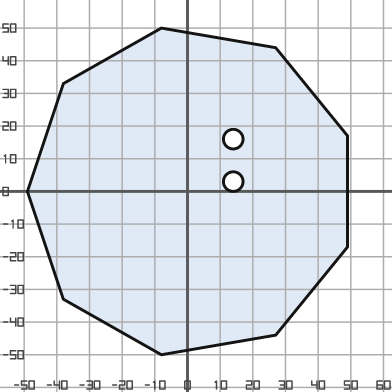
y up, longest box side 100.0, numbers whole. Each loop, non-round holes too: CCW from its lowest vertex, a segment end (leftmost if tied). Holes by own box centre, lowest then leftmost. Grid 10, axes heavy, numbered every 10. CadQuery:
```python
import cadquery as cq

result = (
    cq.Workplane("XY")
    .moveTo(-8.0, -50.0)
    .lineTo(27.0, -44.0)
    .lineTo(49.0, -17.0)
    .lineTo(49.0, 17.0)
    .lineTo(27.0, 44.0)
    .lineTo(-8.0, 50.0)
    .lineTo(-38.0, 33.0)
    .lineTo(-49.0, 0.0)
    .lineTo(-38.0, -33.0)
    .close()
    .moveTo(14.0, 3.0)
    .circle(3.0)
    .moveTo(14.0, 16.0)
    .circle(3.0)
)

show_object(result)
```